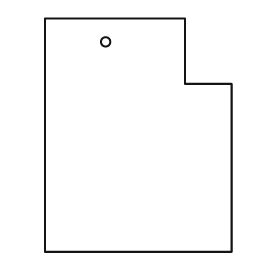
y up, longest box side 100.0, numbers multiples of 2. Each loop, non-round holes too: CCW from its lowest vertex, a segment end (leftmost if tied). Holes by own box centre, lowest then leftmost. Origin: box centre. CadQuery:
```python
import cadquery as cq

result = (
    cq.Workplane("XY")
    .moveTo(-40.0, -50.0)
    .lineTo(40.0, -50.0)
    .lineTo(40.0, 22.0)
    .lineTo(20.0, 22.0)
    .lineTo(20.0, 50.0)
    .lineTo(-40.0, 50.0)
    .close()
    .moveTo(-14.0, 40.0)
    .circle(2.0)
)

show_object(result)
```